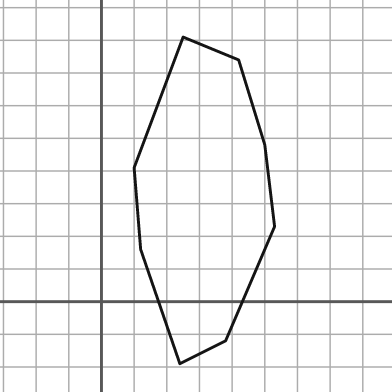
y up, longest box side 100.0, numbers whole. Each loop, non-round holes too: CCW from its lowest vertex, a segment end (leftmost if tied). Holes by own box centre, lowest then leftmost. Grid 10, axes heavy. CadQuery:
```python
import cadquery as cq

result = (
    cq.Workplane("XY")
    .moveTo(24.0, -19.0)
    .lineTo(38.0, -12.0)
    .lineTo(53.0, 23.0)
    .lineTo(50.0, 48.0)
    .lineTo(42.0, 74.0)
    .lineTo(25.0, 81.0)
    .lineTo(10.0, 41.0)
    .lineTo(12.0, 16.0)
    .close()
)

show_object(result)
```